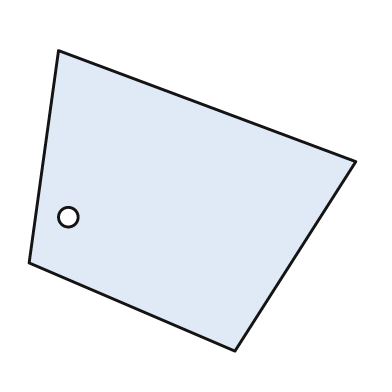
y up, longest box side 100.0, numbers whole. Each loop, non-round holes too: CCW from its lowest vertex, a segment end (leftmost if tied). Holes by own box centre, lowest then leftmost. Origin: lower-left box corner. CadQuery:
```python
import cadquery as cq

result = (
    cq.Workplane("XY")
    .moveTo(63.0, 0.0)
    .lineTo(100.0, 58.0)
    .lineTo(9.0, 92.0)
    .lineTo(0.0, 27.0)
    .close()
    .moveTo(12.0, 41.0)
    .circle(3.0)
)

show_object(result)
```